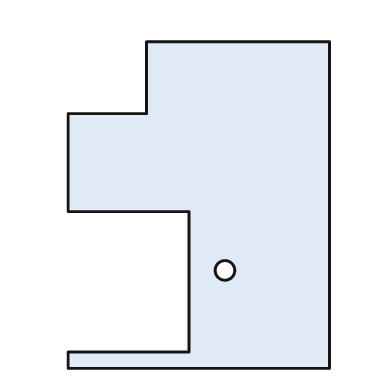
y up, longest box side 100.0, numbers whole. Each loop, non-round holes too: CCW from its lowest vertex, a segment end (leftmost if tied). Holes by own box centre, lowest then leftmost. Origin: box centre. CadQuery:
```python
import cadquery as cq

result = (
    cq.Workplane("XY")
    .moveTo(-40.0, -50.0)
    .lineTo(40.0, -50.0)
    .lineTo(40.0, 50.0)
    .lineTo(-16.0, 50.0)
    .lineTo(-16.0, 28.0)
    .lineTo(-40.0, 28.0)
    .lineTo(-40.0, -2.0)
    .lineTo(-3.0, -2.0)
    .lineTo(-3.0, -45.0)
    .lineTo(-40.0, -45.0)
    .close()
    .moveTo(8.0, -20.0)
    .circle(3.0)
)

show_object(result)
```